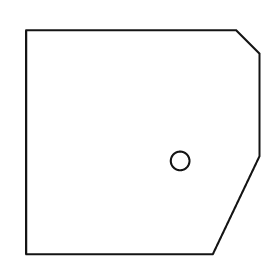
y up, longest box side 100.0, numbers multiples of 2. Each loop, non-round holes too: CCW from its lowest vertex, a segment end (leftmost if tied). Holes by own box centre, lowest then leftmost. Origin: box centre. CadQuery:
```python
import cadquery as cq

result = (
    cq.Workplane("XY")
    .moveTo(-50.0, -48.0)
    .lineTo(30.0, -48.0)
    .lineTo(50.0, -6.0)
    .lineTo(50.0, 38.0)
    .lineTo(40.0, 48.0)
    .lineTo(-50.0, 48.0)
    .close()
    .moveTo(16.0, -8.0)
    .circle(4.0)
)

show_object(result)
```